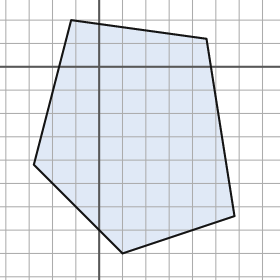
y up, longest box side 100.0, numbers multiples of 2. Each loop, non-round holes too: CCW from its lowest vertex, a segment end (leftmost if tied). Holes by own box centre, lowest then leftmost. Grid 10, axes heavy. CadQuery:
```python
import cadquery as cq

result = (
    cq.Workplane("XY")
    .moveTo(10.0, -80.0)
    .lineTo(58.0, -64.0)
    .lineTo(46.0, 12.0)
    .lineTo(-12.0, 20.0)
    .lineTo(-28.0, -42.0)
    .close()
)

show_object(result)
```